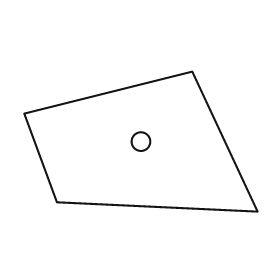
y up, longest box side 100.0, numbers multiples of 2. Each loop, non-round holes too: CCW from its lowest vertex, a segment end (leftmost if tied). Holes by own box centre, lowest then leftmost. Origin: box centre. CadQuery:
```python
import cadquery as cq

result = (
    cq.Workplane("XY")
    .moveTo(50.0, -30.0)
    .lineTo(22.0, 30.0)
    .lineTo(-50.0, 12.0)
    .lineTo(-36.0, -26.0)
    .close()
    .moveTo(0.0, 0.0)
    .circle(4.0)
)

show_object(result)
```